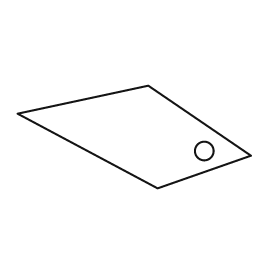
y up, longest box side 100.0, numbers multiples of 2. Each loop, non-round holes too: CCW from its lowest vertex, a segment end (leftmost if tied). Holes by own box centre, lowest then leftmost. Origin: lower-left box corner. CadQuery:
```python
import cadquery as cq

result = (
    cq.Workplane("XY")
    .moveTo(60.0, 0.0)
    .lineTo(100.0, 14.0)
    .lineTo(56.0, 44.0)
    .lineTo(0.0, 32.0)
    .close()
    .moveTo(80.0, 16.0)
    .circle(4.0)
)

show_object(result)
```